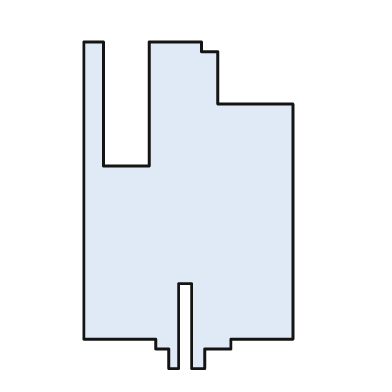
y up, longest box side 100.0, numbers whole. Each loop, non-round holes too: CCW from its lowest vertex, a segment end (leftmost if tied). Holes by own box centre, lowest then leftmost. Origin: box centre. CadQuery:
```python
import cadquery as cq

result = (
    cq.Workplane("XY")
    .moveTo(-6.0, -50.0)
    .lineTo(-3.0, -50.0)
    .lineTo(-3.0, -24.0)
    .lineTo(1.0, -24.0)
    .lineTo(1.0, -50.0)
    .lineTo(5.0, -50.0)
    .lineTo(5.0, -44.0)
    .lineTo(13.0, -44.0)
    .lineTo(13.0, -41.0)
    .lineTo(32.0, -41.0)
    .lineTo(32.0, 31.0)
    .lineTo(9.0, 31.0)
    .lineTo(9.0, 47.0)
    .lineTo(4.0, 47.0)
    .lineTo(4.0, 50.0)
    .lineTo(-12.0, 50.0)
    .lineTo(-12.0, 12.0)
    .lineTo(-26.0, 12.0)
    .lineTo(-26.0, 50.0)
    .lineTo(-32.0, 50.0)
    .lineTo(-32.0, -41.0)
    .lineTo(-10.0, -41.0)
    .lineTo(-10.0, -44.0)
    .lineTo(-6.0, -44.0)
    .close()
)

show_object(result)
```